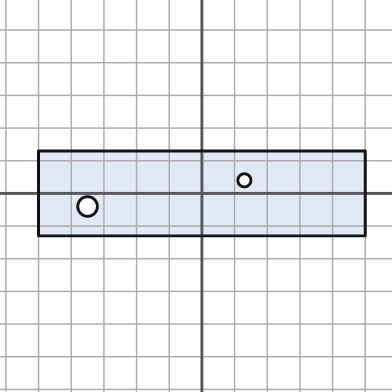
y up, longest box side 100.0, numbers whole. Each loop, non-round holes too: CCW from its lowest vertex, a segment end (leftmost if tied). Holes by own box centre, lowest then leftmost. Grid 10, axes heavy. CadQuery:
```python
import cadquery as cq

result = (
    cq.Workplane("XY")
    .moveTo(-50.0, -13.0)
    .lineTo(50.0, -13.0)
    .lineTo(50.0, 13.0)
    .lineTo(-50.0, 13.0)
    .close()
    .moveTo(-35.0, -4.0)
    .circle(3.0)
    .moveTo(13.0, 4.0)
    .circle(2.0)
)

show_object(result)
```